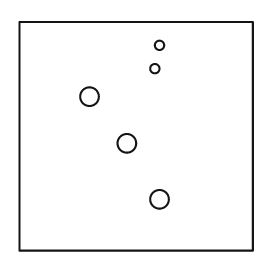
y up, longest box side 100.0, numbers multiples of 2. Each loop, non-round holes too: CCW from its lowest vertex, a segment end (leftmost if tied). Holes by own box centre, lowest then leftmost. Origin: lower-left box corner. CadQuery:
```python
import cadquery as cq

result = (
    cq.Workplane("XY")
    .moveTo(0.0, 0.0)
    .lineTo(100.0, 0.0)
    .lineTo(100.0, 98.0)
    .lineTo(0.0, 98.0)
    .close()
    .moveTo(60.0, 22.0)
    .circle(4.0)
    .moveTo(46.0, 46.0)
    .circle(4.0)
    .moveTo(30.0, 66.0)
    .circle(4.0)
    .moveTo(58.0, 78.0)
    .circle(2.0)
    .moveTo(60.0, 88.0)
    .circle(2.0)
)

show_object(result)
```